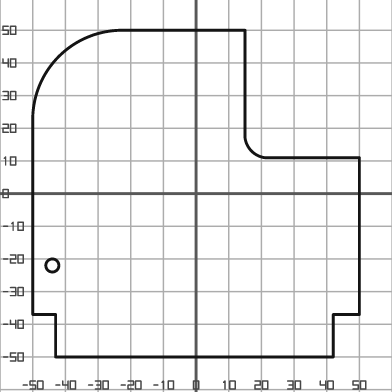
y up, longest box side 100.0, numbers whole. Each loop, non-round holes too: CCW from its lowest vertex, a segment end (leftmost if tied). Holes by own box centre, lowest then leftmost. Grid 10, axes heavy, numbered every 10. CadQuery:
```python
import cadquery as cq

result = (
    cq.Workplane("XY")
    .moveTo(-43.0, -50.0)
    .lineTo(42.0, -50.0)
    .lineTo(42.0, -37.0)
    .lineTo(50.0, -37.0)
    .lineTo(50.0, 11.0)
    .lineTo(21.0, 11.0)
    .threePointArc((17.0, 13.0), (15.0, 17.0))
    .lineTo(15.0, 50.0)
    .lineTo(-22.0, 50.0)
    .threePointArc((-42.0, 42.0), (-50.0, 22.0))
    .lineTo(-50.0, -37.0)
    .lineTo(-43.0, -37.0)
    .close()
    .moveTo(-44.0, -22.0)
    .circle(2.0)
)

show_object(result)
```